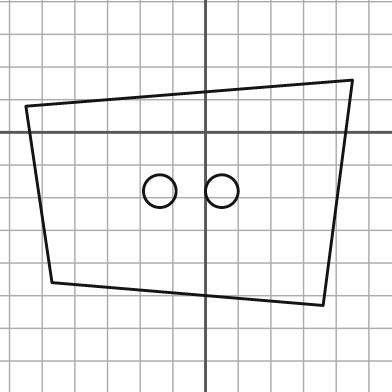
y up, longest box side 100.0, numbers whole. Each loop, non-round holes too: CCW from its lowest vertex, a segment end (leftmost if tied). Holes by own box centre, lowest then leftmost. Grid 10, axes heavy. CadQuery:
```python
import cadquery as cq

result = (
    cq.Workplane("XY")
    .moveTo(36.0, -53.0)
    .lineTo(45.0, 16.0)
    .lineTo(-55.0, 8.0)
    .lineTo(-47.0, -46.0)
    .close()
    .moveTo(-14.0, -18.0)
    .circle(5.0)
    .moveTo(5.0, -18.0)
    .circle(5.0)
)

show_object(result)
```